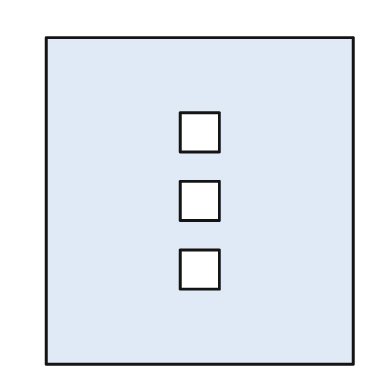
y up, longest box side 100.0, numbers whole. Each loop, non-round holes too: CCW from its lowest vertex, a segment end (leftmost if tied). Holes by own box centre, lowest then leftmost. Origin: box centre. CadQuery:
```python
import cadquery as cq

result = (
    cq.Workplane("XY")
    .moveTo(-47.0, -50.0)
    .lineTo(47.0, -50.0)
    .lineTo(47.0, 50.0)
    .lineTo(-47.0, 50.0)
    .close()
    .moveTo(-6.0, -27.0)
    .lineTo(6.0, -27.0)
    .lineTo(6.0, -15.0)
    .lineTo(-6.0, -15.0)
    .close()
    .moveTo(-6.0, -6.0)
    .lineTo(6.0, -6.0)
    .lineTo(6.0, 6.0)
    .lineTo(-6.0, 6.0)
    .close()
    .moveTo(-6.0, 15.0)
    .lineTo(6.0, 15.0)
    .lineTo(6.0, 27.0)
    .lineTo(-6.0, 27.0)
    .close()
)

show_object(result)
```